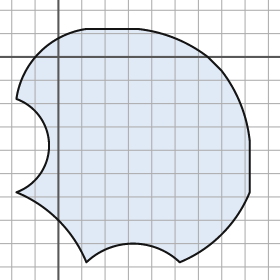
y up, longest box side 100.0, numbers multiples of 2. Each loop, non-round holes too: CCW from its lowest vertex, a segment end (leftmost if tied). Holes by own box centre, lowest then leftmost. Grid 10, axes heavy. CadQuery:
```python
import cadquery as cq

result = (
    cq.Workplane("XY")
    .moveTo(12.0, -88.0)
    .threePointArc((32.0, -80.0), (52.0, -88.0))
    .threePointArc((70.0, -76.0), (82.0, -58.0))
    .lineTo(82.0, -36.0)
    .threePointArc((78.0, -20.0), (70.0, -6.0))
    .lineTo(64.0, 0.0)
    .threePointArc((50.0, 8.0), (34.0, 12.0))
    .lineTo(12.0, 12.0)
    .threePointArc((-8.0, 2.0), (-18.0, -18.0))
    .threePointArc((-4.0, -38.0), (-18.0, -58.0))
    .threePointArc((0.0, -70.0), (12.0, -88.0))
    .close()
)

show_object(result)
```